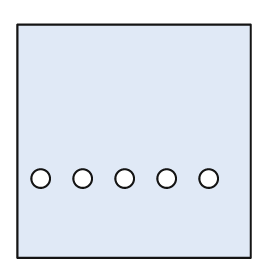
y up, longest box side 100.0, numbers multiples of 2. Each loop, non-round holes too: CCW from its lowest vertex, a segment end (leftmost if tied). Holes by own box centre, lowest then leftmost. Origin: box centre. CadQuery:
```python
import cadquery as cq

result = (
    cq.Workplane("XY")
    .moveTo(-50.0, -50.0)
    .lineTo(50.0, -50.0)
    .lineTo(50.0, 50.0)
    .lineTo(-50.0, 50.0)
    .close()
    .moveTo(-40.0, -16.0)
    .circle(4.0)
    .moveTo(-22.0, -16.0)
    .circle(4.0)
    .moveTo(-4.0, -16.0)
    .circle(4.0)
    .moveTo(14.0, -16.0)
    .circle(4.0)
    .moveTo(32.0, -16.0)
    .circle(4.0)
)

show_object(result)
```